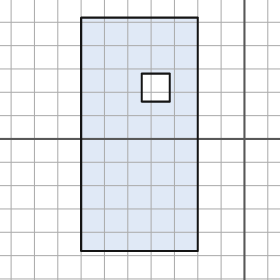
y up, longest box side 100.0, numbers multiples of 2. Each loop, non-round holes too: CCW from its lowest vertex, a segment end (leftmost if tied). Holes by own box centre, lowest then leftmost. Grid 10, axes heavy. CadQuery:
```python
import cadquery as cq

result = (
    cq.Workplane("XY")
    .moveTo(-70.0, -48.0)
    .lineTo(-20.0, -48.0)
    .lineTo(-20.0, 52.0)
    .lineTo(-70.0, 52.0)
    .close()
    .moveTo(-44.0, 16.0)
    .lineTo(-32.0, 16.0)
    .lineTo(-32.0, 28.0)
    .lineTo(-44.0, 28.0)
    .close()
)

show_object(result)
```